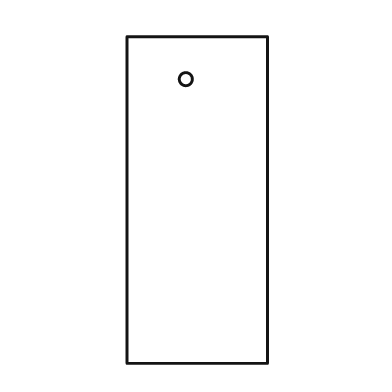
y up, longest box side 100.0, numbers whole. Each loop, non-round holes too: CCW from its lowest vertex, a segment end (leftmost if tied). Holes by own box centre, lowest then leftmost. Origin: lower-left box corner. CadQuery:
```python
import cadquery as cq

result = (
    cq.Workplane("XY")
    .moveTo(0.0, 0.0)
    .lineTo(43.0, 0.0)
    .lineTo(43.0, 100.0)
    .lineTo(0.0, 100.0)
    .close()
    .moveTo(18.0, 87.0)
    .circle(2.0)
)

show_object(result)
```